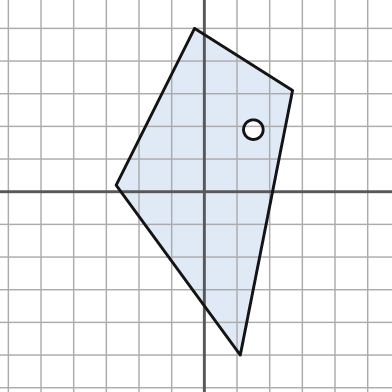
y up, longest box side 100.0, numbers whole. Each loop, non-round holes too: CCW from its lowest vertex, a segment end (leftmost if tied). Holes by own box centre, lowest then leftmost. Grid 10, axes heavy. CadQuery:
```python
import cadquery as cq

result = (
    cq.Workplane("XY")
    .moveTo(11.0, -50.0)
    .lineTo(27.0, 31.0)
    .lineTo(-3.0, 50.0)
    .lineTo(-27.0, 2.0)
    .close()
    .moveTo(15.0, 19.0)
    .circle(3.0)
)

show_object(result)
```